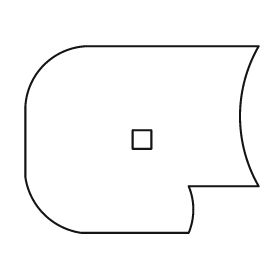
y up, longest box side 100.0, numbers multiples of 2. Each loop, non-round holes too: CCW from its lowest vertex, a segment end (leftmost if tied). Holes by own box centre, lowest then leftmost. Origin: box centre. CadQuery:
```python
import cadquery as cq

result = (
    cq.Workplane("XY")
    .moveTo(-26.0, -40.0)
    .lineTo(20.0, -40.0)
    .threePointArc((22.0, -30.0), (20.0, -20.0))
    .lineTo(50.0, -20.0)
    .threePointArc((42.0, 10.0), (50.0, 40.0))
    .lineTo(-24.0, 40.0)
    .threePointArc((-42.0, 32.0), (-50.0, 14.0))
    .lineTo(-50.0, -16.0)
    .threePointArc((-42.0, -32.0), (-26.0, -40.0))
    .close()
    .moveTo(-4.0, -4.0)
    .lineTo(4.0, -4.0)
    .lineTo(4.0, 4.0)
    .lineTo(-4.0, 4.0)
    .close()
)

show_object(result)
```